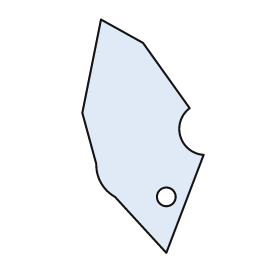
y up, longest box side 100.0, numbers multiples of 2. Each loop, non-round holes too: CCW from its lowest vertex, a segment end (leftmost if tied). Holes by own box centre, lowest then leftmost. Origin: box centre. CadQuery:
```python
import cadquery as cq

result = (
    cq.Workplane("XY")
    .moveTo(10.0, -50.0)
    .lineTo(26.0, -8.0)
    .threePointArc((16.0, 0.0), (20.0, 12.0))
    .lineTo(0.0, 40.0)
    .lineTo(-18.0, 50.0)
    .lineTo(-26.0, 10.0)
    .lineTo(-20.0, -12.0)
    .threePointArc((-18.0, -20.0), (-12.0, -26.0))
    .close()
    .moveTo(10.0, -26.0)
    .circle(4.0)
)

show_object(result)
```